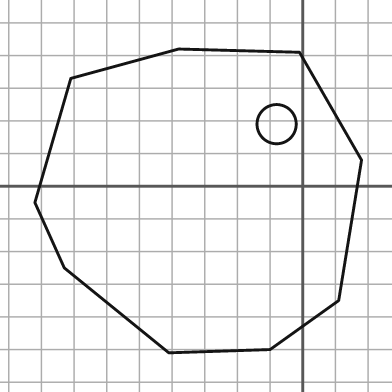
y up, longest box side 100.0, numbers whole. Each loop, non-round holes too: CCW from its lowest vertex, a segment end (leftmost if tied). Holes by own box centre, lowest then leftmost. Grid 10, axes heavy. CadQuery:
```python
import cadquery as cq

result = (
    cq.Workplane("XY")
    .moveTo(-41.0, -51.0)
    .lineTo(-10.0, -50.0)
    .lineTo(11.0, -35.0)
    .lineTo(18.0, 8.0)
    .lineTo(-1.0, 41.0)
    .lineTo(-38.0, 42.0)
    .lineTo(-71.0, 33.0)
    .lineTo(-82.0, -5.0)
    .lineTo(-73.0, -25.0)
    .close()
    .moveTo(-8.0, 19.0)
    .circle(6.0)
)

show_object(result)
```